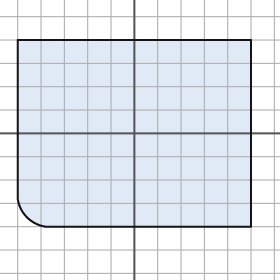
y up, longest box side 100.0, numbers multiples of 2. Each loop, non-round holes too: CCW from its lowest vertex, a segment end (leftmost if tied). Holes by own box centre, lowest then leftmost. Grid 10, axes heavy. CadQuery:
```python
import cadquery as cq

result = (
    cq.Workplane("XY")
    .moveTo(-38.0, -40.0)
    .lineTo(50.0, -40.0)
    .lineTo(50.0, 40.0)
    .lineTo(-50.0, 40.0)
    .lineTo(-50.0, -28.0)
    .threePointArc((-46.0, -36.0), (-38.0, -40.0))
    .close()
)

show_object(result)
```